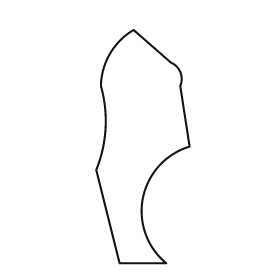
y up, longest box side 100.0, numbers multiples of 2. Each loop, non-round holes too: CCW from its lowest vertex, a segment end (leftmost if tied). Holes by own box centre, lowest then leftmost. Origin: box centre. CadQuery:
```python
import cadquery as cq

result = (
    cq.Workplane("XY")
    .moveTo(-10.0, -50.0)
    .lineTo(10.0, -50.0)
    .threePointArc((0.0, -22.0), (20.0, 0.0))
    .lineTo(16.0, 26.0)
    .threePointArc((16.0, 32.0), (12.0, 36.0))
    .lineTo(-4.0, 50.0)
    .threePointArc((-14.0, 40.0), (-18.0, 26.0))
    .threePointArc((-16.0, 8.0), (-20.0, -10.0))
    .close()
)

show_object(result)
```